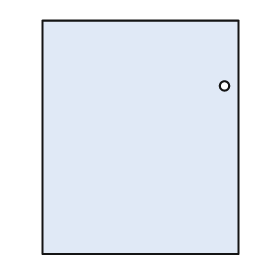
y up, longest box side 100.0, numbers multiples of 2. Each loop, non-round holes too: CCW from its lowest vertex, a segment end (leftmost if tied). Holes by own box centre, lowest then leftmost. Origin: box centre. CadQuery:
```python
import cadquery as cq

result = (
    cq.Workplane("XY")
    .moveTo(-42.0, -50.0)
    .lineTo(42.0, -50.0)
    .lineTo(42.0, 50.0)
    .lineTo(-42.0, 50.0)
    .close()
    .moveTo(36.0, 22.0)
    .circle(2.0)
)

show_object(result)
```